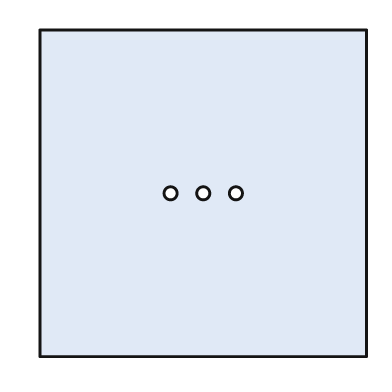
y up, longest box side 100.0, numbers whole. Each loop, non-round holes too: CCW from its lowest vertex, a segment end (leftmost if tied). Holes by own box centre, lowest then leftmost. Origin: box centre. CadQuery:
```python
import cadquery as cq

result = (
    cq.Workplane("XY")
    .moveTo(-50.0, -50.0)
    .lineTo(50.0, -50.0)
    .lineTo(50.0, 50.0)
    .lineTo(-50.0, 50.0)
    .close()
    .moveTo(-10.0, 0.0)
    .circle(2.0)
    .moveTo(0.0, 0.0)
    .circle(2.0)
    .moveTo(10.0, 0.0)
    .circle(2.0)
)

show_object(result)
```